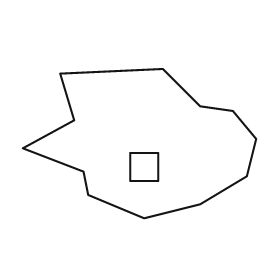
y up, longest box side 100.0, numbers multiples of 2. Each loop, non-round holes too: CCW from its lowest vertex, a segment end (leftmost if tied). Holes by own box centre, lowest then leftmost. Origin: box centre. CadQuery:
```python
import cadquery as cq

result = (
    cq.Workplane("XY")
    .moveTo(2.0, -32.0)
    .lineTo(26.0, -26.0)
    .lineTo(46.0, -14.0)
    .lineTo(50.0, 2.0)
    .lineTo(40.0, 14.0)
    .lineTo(26.0, 16.0)
    .lineTo(10.0, 32.0)
    .lineTo(-34.0, 30.0)
    .lineTo(-28.0, 10.0)
    .lineTo(-50.0, -2.0)
    .lineTo(-24.0, -12.0)
    .lineTo(-22.0, -22.0)
    .close()
    .moveTo(-4.0, -16.0)
    .lineTo(8.0, -16.0)
    .lineTo(8.0, -4.0)
    .lineTo(-4.0, -4.0)
    .close()
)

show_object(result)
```